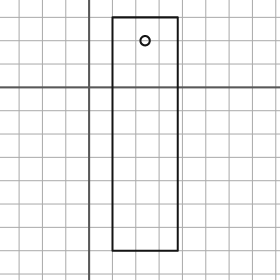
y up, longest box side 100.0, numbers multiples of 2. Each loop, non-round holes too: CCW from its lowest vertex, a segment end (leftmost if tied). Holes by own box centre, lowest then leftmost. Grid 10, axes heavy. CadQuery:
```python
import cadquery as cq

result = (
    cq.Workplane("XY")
    .moveTo(10.0, -70.0)
    .lineTo(38.0, -70.0)
    .lineTo(38.0, 30.0)
    .lineTo(10.0, 30.0)
    .close()
    .moveTo(24.0, 20.0)
    .circle(2.0)
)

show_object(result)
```